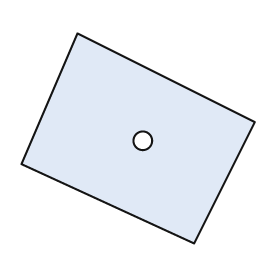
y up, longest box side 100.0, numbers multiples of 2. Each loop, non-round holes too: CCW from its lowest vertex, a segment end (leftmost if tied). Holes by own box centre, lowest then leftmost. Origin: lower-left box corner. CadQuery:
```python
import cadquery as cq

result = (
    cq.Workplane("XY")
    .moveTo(74.0, 0.0)
    .lineTo(100.0, 52.0)
    .lineTo(24.0, 90.0)
    .lineTo(0.0, 34.0)
    .close()
    .moveTo(52.0, 44.0)
    .circle(4.0)
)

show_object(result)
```